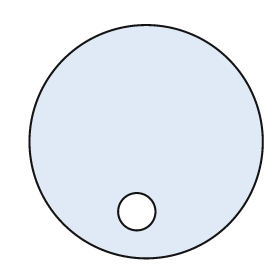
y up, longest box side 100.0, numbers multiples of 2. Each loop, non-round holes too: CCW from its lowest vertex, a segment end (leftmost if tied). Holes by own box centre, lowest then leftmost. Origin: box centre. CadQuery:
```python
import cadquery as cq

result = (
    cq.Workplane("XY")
    .moveTo(0.0, 0.0)
    .circle(50.0)
    .moveTo(-4.0, -30.0)
    .circle(8.0)
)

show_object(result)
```